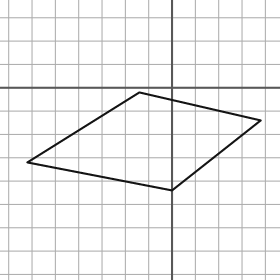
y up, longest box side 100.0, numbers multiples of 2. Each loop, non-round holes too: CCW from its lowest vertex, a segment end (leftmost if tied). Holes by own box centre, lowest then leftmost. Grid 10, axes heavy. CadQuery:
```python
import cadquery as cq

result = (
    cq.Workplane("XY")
    .moveTo(0.0, -44.0)
    .lineTo(38.0, -14.0)
    .lineTo(-14.0, -2.0)
    .lineTo(-62.0, -32.0)
    .close()
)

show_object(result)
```